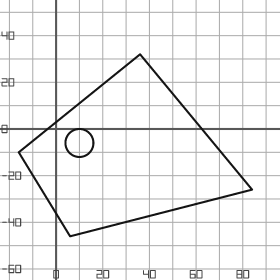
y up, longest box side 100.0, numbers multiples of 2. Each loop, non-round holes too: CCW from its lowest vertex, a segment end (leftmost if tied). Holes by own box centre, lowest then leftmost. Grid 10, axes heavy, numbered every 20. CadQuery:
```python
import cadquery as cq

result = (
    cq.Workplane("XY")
    .moveTo(6.0, -46.0)
    .lineTo(84.0, -26.0)
    .lineTo(36.0, 32.0)
    .lineTo(-16.0, -10.0)
    .close()
    .moveTo(10.0, -6.0)
    .circle(6.0)
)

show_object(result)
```